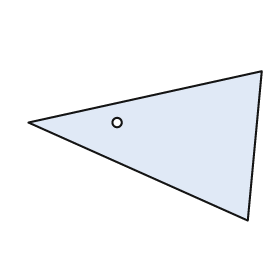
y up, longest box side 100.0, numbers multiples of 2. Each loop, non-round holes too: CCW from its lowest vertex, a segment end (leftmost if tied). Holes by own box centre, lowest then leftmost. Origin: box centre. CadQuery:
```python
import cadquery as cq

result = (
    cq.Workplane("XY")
    .moveTo(44.0, -32.0)
    .lineTo(50.0, 32.0)
    .lineTo(-50.0, 10.0)
    .close()
    .moveTo(-12.0, 10.0)
    .circle(2.0)
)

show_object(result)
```